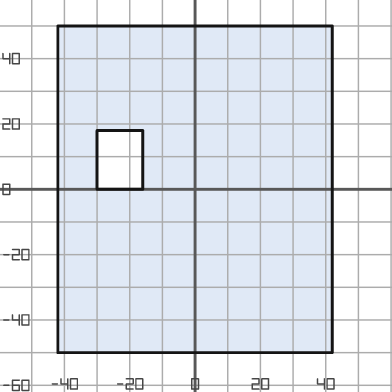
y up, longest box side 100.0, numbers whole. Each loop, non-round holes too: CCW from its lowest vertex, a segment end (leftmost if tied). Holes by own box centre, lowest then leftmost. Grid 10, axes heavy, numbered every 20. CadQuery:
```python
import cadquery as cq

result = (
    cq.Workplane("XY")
    .moveTo(-42.0, -50.0)
    .lineTo(42.0, -50.0)
    .lineTo(42.0, 50.0)
    .lineTo(-42.0, 50.0)
    .close()
    .moveTo(-30.0, 0.0)
    .lineTo(-16.0, 0.0)
    .lineTo(-16.0, 18.0)
    .lineTo(-30.0, 18.0)
    .close()
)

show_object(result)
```